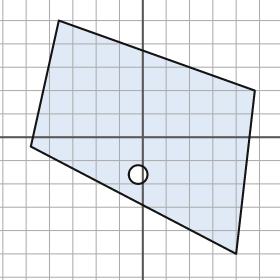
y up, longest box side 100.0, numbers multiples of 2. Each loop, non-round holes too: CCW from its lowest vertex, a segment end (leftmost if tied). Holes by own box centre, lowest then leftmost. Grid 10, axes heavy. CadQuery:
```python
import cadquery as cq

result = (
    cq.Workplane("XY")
    .moveTo(40.0, -50.0)
    .lineTo(48.0, 20.0)
    .lineTo(-36.0, 50.0)
    .lineTo(-48.0, -4.0)
    .close()
    .moveTo(-2.0, -16.0)
    .circle(4.0)
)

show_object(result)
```